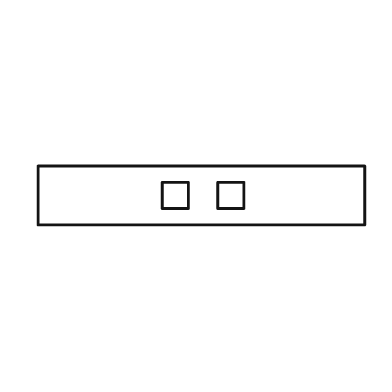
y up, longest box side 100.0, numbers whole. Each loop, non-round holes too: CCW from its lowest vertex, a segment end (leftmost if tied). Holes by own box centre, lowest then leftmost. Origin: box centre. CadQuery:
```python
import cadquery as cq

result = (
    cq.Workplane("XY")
    .moveTo(-50.0, -9.0)
    .lineTo(50.0, -9.0)
    .lineTo(50.0, 9.0)
    .lineTo(-50.0, 9.0)
    .close()
    .moveTo(-12.0, -4.0)
    .lineTo(-4.0, -4.0)
    .lineTo(-4.0, 4.0)
    .lineTo(-12.0, 4.0)
    .close()
    .moveTo(5.0, -4.0)
    .lineTo(13.0, -4.0)
    .lineTo(13.0, 4.0)
    .lineTo(5.0, 4.0)
    .close()
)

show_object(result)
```